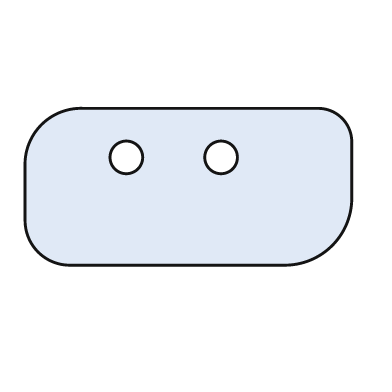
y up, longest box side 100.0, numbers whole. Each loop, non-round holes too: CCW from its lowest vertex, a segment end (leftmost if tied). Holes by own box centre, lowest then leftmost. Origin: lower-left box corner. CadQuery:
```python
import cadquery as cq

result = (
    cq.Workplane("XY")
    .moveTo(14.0, 0.0)
    .lineTo(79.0, 0.0)
    .threePointArc((94.0, 6.0), (100.0, 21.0))
    .lineTo(100.0, 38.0)
    .threePointArc((97.0, 45.0), (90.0, 48.0))
    .lineTo(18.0, 48.0)
    .threePointArc((5.0, 43.0), (0.0, 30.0))
    .lineTo(0.0, 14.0)
    .threePointArc((4.0, 4.0), (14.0, 0.0))
    .close()
    .moveTo(31.0, 33.0)
    .circle(5.0)
    .moveTo(60.0, 33.0)
    .circle(5.0)
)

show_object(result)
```